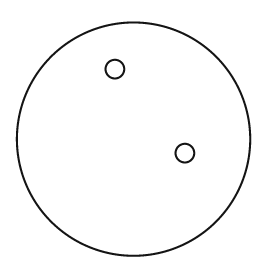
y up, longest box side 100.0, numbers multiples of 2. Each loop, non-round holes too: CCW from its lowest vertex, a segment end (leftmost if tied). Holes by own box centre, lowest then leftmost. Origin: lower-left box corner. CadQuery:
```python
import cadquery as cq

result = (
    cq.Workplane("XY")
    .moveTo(50.0, 50.0)
    .circle(50.0)
    .moveTo(72.0, 44.0)
    .circle(4.0)
    .moveTo(42.0, 80.0)
    .circle(4.0)
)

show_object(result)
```